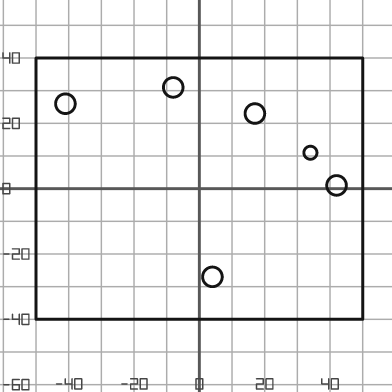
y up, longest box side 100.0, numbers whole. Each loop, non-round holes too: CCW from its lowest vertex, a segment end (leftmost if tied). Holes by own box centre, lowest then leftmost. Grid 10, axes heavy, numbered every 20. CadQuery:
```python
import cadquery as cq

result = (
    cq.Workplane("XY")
    .moveTo(-50.0, -40.0)
    .lineTo(50.0, -40.0)
    .lineTo(50.0, 40.0)
    .lineTo(-50.0, 40.0)
    .close()
    .moveTo(4.0, -27.0)
    .circle(3.0)
    .moveTo(42.0, 1.0)
    .circle(3.0)
    .moveTo(34.0, 11.0)
    .circle(2.0)
    .moveTo(17.0, 23.0)
    .circle(3.0)
    .moveTo(-41.0, 26.0)
    .circle(3.0)
    .moveTo(-8.0, 31.0)
    .circle(3.0)
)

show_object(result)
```